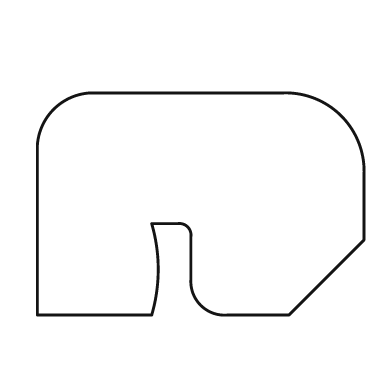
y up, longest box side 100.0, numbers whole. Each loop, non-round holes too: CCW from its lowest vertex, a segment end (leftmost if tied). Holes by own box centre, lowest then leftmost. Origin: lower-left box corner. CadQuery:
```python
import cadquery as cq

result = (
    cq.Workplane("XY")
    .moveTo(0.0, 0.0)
    .lineTo(35.0, 0.0)
    .threePointArc((37.0, 14.0), (35.0, 28.0))
    .lineTo(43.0, 28.0)
    .threePointArc((46.0, 27.0), (47.0, 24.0))
    .lineTo(47.0, 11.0)
    .threePointArc((50.0, 3.0), (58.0, 0.0))
    .lineTo(77.0, 0.0)
    .lineTo(100.0, 23.0)
    .lineTo(100.0, 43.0)
    .threePointArc((93.0, 61.0), (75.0, 68.0))
    .lineTo(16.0, 68.0)
    .threePointArc((5.0, 63.0), (0.0, 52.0))
    .close()
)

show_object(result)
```